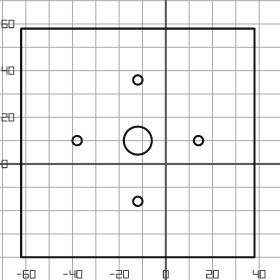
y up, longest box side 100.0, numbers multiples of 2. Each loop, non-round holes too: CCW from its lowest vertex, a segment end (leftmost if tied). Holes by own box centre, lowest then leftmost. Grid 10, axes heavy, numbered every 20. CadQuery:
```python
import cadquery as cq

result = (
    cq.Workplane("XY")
    .moveTo(-62.0, -40.0)
    .lineTo(38.0, -40.0)
    .lineTo(38.0, 58.0)
    .lineTo(-62.0, 58.0)
    .close()
    .moveTo(-12.0, -16.0)
    .circle(2.0)
    .moveTo(-38.0, 10.0)
    .circle(2.0)
    .moveTo(-12.0, 10.0)
    .circle(6.0)
    .moveTo(14.0, 10.0)
    .circle(2.0)
    .moveTo(-12.0, 36.0)
    .circle(2.0)
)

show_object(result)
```